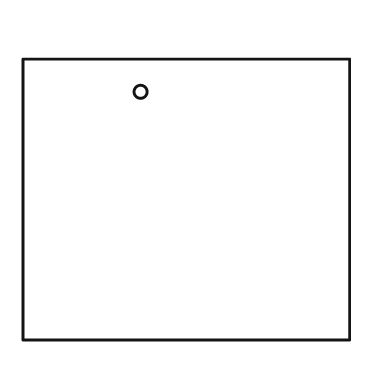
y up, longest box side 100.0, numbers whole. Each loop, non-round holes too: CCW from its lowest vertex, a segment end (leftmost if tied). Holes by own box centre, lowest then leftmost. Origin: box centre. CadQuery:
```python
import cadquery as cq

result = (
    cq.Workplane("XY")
    .moveTo(-50.0, -43.0)
    .lineTo(50.0, -43.0)
    .lineTo(50.0, 43.0)
    .lineTo(-50.0, 43.0)
    .close()
    .moveTo(-14.0, 33.0)
    .circle(2.0)
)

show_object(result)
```